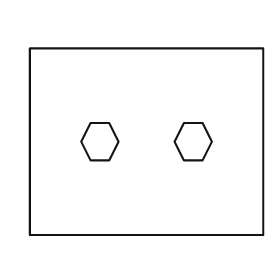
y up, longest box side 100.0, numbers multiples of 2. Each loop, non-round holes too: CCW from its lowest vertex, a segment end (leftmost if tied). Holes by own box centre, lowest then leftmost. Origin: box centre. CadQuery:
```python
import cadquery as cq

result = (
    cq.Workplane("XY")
    .moveTo(-50.0, -40.0)
    .lineTo(50.0, -40.0)
    .lineTo(50.0, 40.0)
    .lineTo(-50.0, 40.0)
    .close()
    .moveTo(-24.0, -8.0)
    .lineTo(-16.0, -8.0)
    .lineTo(-12.0, 0.0)
    .lineTo(-16.0, 8.0)
    .lineTo(-24.0, 8.0)
    .lineTo(-28.0, 0.0)
    .close()
    .moveTo(16.0, -8.0)
    .lineTo(24.0, -8.0)
    .lineTo(28.0, 0.0)
    .lineTo(24.0, 8.0)
    .lineTo(16.0, 8.0)
    .lineTo(12.0, 0.0)
    .close()
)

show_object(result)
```